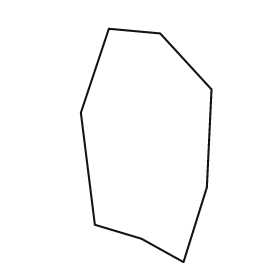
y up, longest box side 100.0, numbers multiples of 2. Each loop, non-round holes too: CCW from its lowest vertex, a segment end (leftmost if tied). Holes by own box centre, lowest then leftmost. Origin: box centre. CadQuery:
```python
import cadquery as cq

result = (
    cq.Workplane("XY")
    .moveTo(16.0, -50.0)
    .lineTo(26.0, -18.0)
    .lineTo(28.0, 24.0)
    .lineTo(6.0, 48.0)
    .lineTo(-16.0, 50.0)
    .lineTo(-28.0, 14.0)
    .lineTo(-22.0, -34.0)
    .lineTo(-2.0, -40.0)
    .close()
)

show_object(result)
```